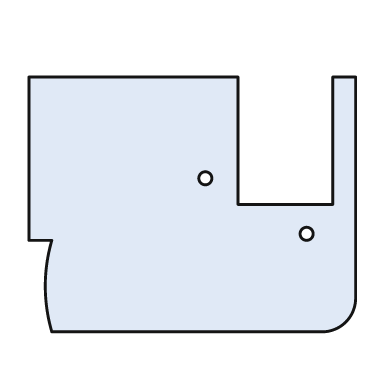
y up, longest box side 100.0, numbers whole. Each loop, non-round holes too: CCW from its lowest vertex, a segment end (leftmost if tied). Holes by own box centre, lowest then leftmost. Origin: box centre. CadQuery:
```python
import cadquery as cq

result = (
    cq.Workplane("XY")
    .moveTo(-43.0, -39.0)
    .lineTo(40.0, -39.0)
    .threePointArc((47.0, -36.0), (50.0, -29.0))
    .lineTo(50.0, 39.0)
    .lineTo(43.0, 39.0)
    .lineTo(43.0, 0.0)
    .lineTo(14.0, 0.0)
    .lineTo(14.0, 39.0)
    .lineTo(-50.0, 39.0)
    .lineTo(-50.0, -11.0)
    .lineTo(-43.0, -11.0)
    .threePointArc((-45.0, -25.0), (-43.0, -39.0))
    .close()
    .moveTo(35.0, -9.0)
    .circle(2.0)
    .moveTo(4.0, 8.0)
    .circle(2.0)
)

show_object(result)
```